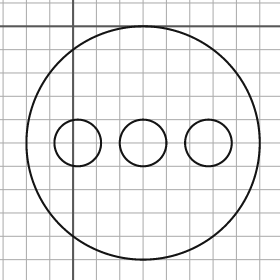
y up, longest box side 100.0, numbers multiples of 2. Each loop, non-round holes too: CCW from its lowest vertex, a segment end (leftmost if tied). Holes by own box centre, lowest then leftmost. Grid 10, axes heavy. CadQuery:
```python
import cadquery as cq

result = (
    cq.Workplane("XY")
    .moveTo(30.0, -50.0)
    .circle(50.0)
    .moveTo(2.0, -50.0)
    .circle(10.0)
    .moveTo(30.0, -50.0)
    .circle(10.0)
    .moveTo(58.0, -50.0)
    .circle(10.0)
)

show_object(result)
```